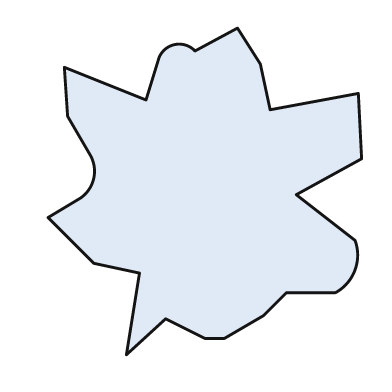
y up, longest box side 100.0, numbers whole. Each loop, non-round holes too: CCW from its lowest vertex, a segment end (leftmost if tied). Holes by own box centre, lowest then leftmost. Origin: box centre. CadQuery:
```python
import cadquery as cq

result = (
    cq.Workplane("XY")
    .moveTo(-24.0, -50.0)
    .lineTo(-12.0, -39.0)
    .lineTo(0.0, -45.0)
    .lineTo(6.0, -45.0)
    .lineTo(18.0, -38.0)
    .lineTo(25.0, -31.0)
    .lineTo(40.0, -31.0)
    .threePointArc((46.0, -24.0), (46.0, -15.0))
    .lineTo(28.0, -1.0)
    .lineTo(48.0, 10.0)
    .lineTo(47.0, 30.0)
    .lineTo(20.0, 25.0)
    .lineTo(17.0, 39.0)
    .lineTo(10.0, 50.0)
    .lineTo(-3.0, 43.0)
    .threePointArc((-9.0, 45.0), (-14.0, 41.0))
    .lineTo(-18.0, 28.0)
    .lineTo(-43.0, 38.0)
    .lineTo(-42.0, 23.0)
    .lineTo(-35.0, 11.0)
    .threePointArc((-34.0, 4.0), (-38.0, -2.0))
    .lineTo(-48.0, -8.0)
    .lineTo(-34.0, -22.0)
    .lineTo(-20.0, -25.0)
    .close()
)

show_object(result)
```